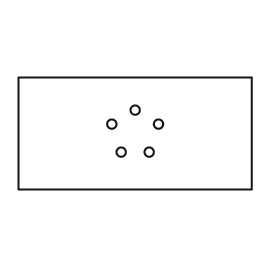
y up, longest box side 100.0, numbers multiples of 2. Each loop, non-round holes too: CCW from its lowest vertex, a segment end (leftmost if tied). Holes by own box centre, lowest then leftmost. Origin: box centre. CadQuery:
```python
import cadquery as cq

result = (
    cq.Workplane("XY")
    .moveTo(-50.0, -24.0)
    .lineTo(50.0, -24.0)
    .lineTo(50.0, 24.0)
    .lineTo(-50.0, 24.0)
    .close()
    .moveTo(-6.0, -8.0)
    .circle(2.0)
    .moveTo(6.0, -8.0)
    .circle(2.0)
    .moveTo(-10.0, 4.0)
    .circle(2.0)
    .moveTo(10.0, 4.0)
    .circle(2.0)
    .moveTo(0.0, 10.0)
    .circle(2.0)
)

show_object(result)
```